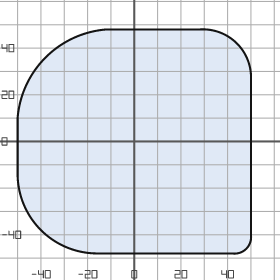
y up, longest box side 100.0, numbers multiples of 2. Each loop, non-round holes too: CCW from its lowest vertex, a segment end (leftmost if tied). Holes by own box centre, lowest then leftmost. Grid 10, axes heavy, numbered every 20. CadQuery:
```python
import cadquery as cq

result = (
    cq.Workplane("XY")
    .moveTo(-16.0, -48.0)
    .lineTo(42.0, -48.0)
    .threePointArc((48.0, -46.0), (50.0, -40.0))
    .lineTo(50.0, 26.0)
    .threePointArc((44.0, 42.0), (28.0, 48.0))
    .lineTo(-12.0, 48.0)
    .threePointArc((-38.0, 36.0), (-50.0, 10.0))
    .lineTo(-50.0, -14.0)
    .threePointArc((-40.0, -38.0), (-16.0, -48.0))
    .close()
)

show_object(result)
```